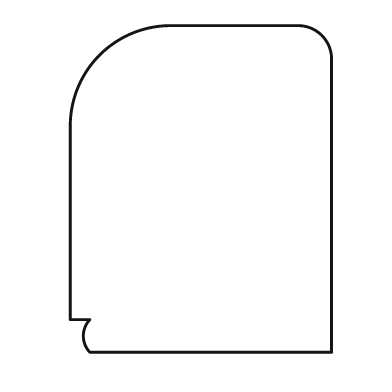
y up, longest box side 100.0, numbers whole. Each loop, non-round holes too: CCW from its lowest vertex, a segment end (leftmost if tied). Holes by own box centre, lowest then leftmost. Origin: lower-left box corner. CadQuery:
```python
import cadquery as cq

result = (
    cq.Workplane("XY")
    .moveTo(6.0, 0.0)
    .lineTo(80.0, 0.0)
    .lineTo(80.0, 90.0)
    .threePointArc((77.0, 97.0), (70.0, 100.0))
    .lineTo(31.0, 100.0)
    .threePointArc((9.0, 91.0), (0.0, 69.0))
    .lineTo(0.0, 10.0)
    .lineTo(6.0, 10.0)
    .threePointArc((4.0, 5.0), (6.0, 0.0))
    .close()
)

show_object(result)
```